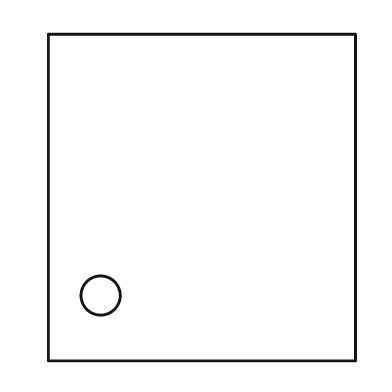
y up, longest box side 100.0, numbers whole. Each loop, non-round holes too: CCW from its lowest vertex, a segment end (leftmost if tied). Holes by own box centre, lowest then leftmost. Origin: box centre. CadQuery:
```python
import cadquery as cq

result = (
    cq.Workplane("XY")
    .moveTo(-47.0, -50.0)
    .lineTo(47.0, -50.0)
    .lineTo(47.0, 50.0)
    .lineTo(-47.0, 50.0)
    .close()
    .moveTo(-31.0, -30.0)
    .circle(6.0)
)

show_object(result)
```